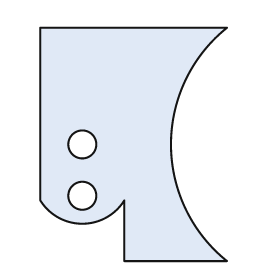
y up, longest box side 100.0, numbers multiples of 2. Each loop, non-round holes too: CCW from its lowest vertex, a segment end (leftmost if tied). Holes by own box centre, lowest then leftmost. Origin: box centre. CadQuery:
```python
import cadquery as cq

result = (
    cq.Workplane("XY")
    .moveTo(-4.0, -50.0)
    .lineTo(40.0, -50.0)
    .threePointArc((16.0, 0.0), (40.0, 50.0))
    .lineTo(-40.0, 50.0)
    .lineTo(-40.0, -24.0)
    .threePointArc((-22.0, -34.0), (-4.0, -24.0))
    .close()
    .moveTo(-22.0, -22.0)
    .circle(6.0)
    .moveTo(-22.0, 0.0)
    .circle(6.0)
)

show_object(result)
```